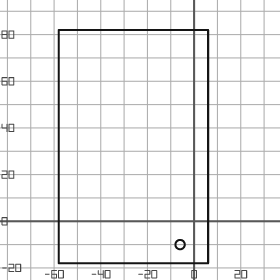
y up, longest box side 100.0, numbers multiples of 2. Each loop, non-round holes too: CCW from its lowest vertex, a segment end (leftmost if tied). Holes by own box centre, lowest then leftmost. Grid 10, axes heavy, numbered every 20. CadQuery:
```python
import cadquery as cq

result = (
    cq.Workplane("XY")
    .moveTo(-58.0, -18.0)
    .lineTo(6.0, -18.0)
    .lineTo(6.0, 82.0)
    .lineTo(-58.0, 82.0)
    .close()
    .moveTo(-6.0, -10.0)
    .circle(2.0)
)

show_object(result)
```